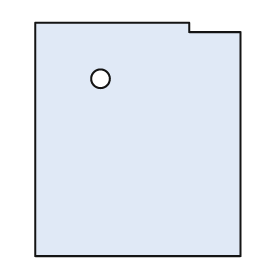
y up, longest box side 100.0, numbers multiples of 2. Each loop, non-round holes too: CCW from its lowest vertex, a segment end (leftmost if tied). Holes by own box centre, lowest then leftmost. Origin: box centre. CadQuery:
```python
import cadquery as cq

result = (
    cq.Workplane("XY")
    .moveTo(-44.0, -50.0)
    .lineTo(44.0, -50.0)
    .lineTo(44.0, 46.0)
    .lineTo(22.0, 46.0)
    .lineTo(22.0, 50.0)
    .lineTo(-44.0, 50.0)
    .close()
    .moveTo(-16.0, 26.0)
    .circle(4.0)
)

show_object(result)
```